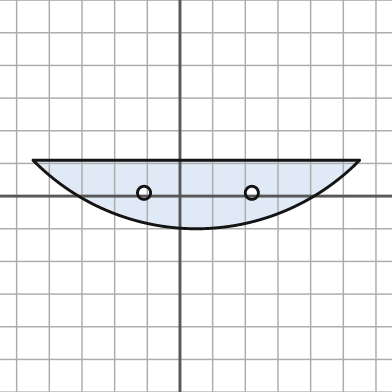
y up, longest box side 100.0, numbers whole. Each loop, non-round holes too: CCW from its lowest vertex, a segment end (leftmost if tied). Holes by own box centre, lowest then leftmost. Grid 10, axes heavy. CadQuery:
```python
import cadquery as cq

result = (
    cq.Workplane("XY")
    .moveTo(-45.0, 11.0)
    .threePointArc((5.0, -10.0), (55.0, 11.0))
    .close()
    .moveTo(-11.0, 1.0)
    .circle(2.0)
    .moveTo(22.0, 1.0)
    .circle(2.0)
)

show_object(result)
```